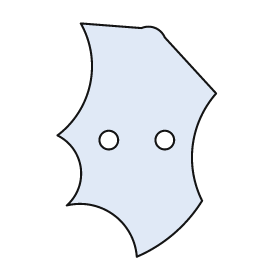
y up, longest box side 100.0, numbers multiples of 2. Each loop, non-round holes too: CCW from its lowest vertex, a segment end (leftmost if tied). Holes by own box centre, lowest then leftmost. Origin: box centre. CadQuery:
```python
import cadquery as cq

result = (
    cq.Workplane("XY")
    .moveTo(0.0, -50.0)
    .threePointArc((16.0, -40.0), (28.0, -26.0))
    .threePointArc((24.0, -2.0), (34.0, 20.0))
    .lineTo(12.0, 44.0)
    .threePointArc((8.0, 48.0), (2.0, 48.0))
    .lineTo(-24.0, 50.0)
    .threePointArc((-20.0, 24.0), (-34.0, 2.0))
    .threePointArc((-24.0, -12.0), (-30.0, -28.0))
    .threePointArc((-10.0, -32.0), (0.0, -50.0))
    .close()
    .moveTo(-12.0, 0.0)
    .circle(4.0)
    .moveTo(12.0, 0.0)
    .circle(4.0)
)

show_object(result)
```